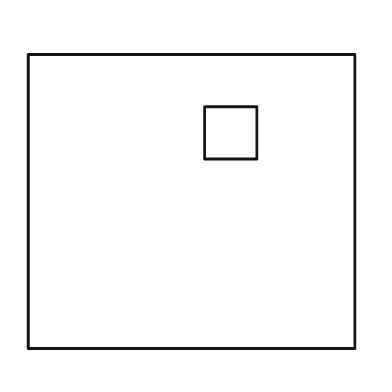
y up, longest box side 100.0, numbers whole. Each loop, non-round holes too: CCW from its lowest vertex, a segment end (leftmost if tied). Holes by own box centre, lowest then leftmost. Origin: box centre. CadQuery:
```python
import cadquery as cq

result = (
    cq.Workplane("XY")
    .moveTo(-50.0, -45.0)
    .lineTo(50.0, -45.0)
    .lineTo(50.0, 45.0)
    .lineTo(-50.0, 45.0)
    .close()
    .moveTo(4.0, 13.0)
    .lineTo(20.0, 13.0)
    .lineTo(20.0, 29.0)
    .lineTo(4.0, 29.0)
    .close()
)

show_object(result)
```